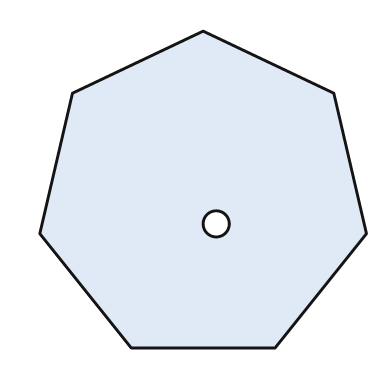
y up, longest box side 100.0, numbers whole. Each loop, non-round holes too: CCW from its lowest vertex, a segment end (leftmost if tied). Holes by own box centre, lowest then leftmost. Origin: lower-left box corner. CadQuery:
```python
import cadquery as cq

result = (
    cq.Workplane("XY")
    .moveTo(28.0, 0.0)
    .lineTo(72.0, 0.0)
    .lineTo(100.0, 35.0)
    .lineTo(90.0, 78.0)
    .lineTo(50.0, 97.0)
    .lineTo(10.0, 78.0)
    .lineTo(0.0, 35.0)
    .close()
    .moveTo(54.0, 38.0)
    .circle(4.0)
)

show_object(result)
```